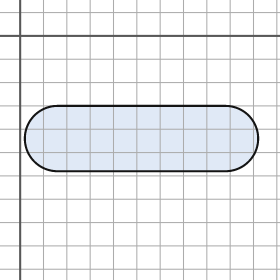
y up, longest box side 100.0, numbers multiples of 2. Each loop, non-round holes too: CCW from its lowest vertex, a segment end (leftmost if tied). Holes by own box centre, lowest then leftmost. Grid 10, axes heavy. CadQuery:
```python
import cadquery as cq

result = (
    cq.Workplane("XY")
    .moveTo(16.0, -58.0)
    .lineTo(88.0, -58.0)
    .threePointArc((102.0, -44.0), (88.0, -30.0))
    .lineTo(16.0, -30.0)
    .threePointArc((2.0, -44.0), (16.0, -58.0))
    .close()
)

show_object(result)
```